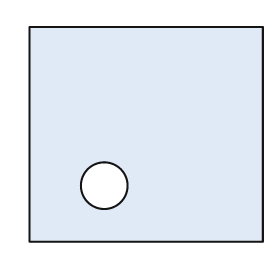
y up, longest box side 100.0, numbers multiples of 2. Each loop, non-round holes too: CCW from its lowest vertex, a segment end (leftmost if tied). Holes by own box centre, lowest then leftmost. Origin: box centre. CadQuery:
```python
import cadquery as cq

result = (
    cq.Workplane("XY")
    .moveTo(-50.0, -46.0)
    .lineTo(50.0, -46.0)
    .lineTo(50.0, 46.0)
    .lineTo(-50.0, 46.0)
    .close()
    .moveTo(-18.0, -22.0)
    .circle(10.0)
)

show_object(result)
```